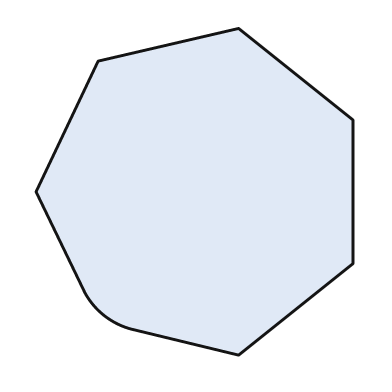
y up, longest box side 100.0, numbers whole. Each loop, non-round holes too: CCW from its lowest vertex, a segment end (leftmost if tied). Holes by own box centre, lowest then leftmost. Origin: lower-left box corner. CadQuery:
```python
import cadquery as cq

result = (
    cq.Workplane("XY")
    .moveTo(62.0, 0.0)
    .lineTo(97.0, 28.0)
    .lineTo(97.0, 72.0)
    .lineTo(62.0, 100.0)
    .lineTo(19.0, 90.0)
    .lineTo(0.0, 50.0)
    .lineTo(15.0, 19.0)
    .threePointArc((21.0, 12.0), (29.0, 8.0))
    .close()
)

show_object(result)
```